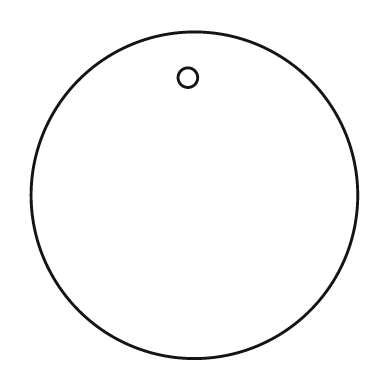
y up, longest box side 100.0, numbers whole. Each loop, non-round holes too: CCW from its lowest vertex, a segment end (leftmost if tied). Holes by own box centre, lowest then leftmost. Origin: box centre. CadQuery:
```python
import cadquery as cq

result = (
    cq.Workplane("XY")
    .moveTo(0.0, 0.0)
    .circle(50.0)
    .moveTo(-2.0, 36.0)
    .circle(3.0)
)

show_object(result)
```